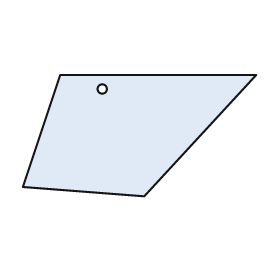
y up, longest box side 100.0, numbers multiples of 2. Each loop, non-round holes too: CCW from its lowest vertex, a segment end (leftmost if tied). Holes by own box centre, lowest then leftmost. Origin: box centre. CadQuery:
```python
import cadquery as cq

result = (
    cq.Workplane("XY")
    .moveTo(2.0, -26.0)
    .lineTo(50.0, 26.0)
    .lineTo(-34.0, 26.0)
    .lineTo(-50.0, -22.0)
    .close()
    .moveTo(-16.0, 20.0)
    .circle(2.0)
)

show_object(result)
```